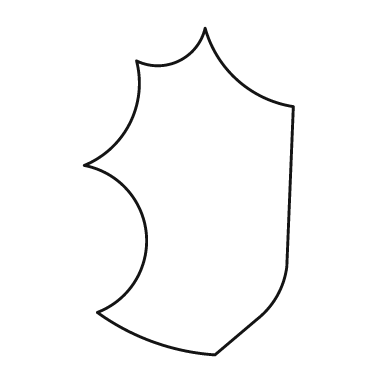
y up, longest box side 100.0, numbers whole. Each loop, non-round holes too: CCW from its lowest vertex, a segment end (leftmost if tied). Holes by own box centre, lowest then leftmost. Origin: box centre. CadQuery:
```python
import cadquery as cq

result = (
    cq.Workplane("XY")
    .moveTo(8.0, -50.0)
    .lineTo(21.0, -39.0)
    .threePointArc((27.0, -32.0), (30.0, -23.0))
    .lineTo(32.0, 26.0)
    .threePointArc((15.0, 34.0), (5.0, 50.0))
    .threePointArc((-3.0, 40.0), (-16.0, 40.0))
    .threePointArc((-18.0, 21.0), (-32.0, 8.0))
    .threePointArc((-13.0, -13.0), (-28.0, -37.0))
    .threePointArc((-11.0, -46.0), (8.0, -50.0))
    .close()
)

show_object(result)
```